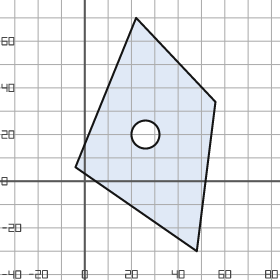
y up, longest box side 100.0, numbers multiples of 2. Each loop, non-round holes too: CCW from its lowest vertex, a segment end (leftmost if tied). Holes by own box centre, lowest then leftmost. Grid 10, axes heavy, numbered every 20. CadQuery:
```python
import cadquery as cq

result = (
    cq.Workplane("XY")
    .moveTo(48.0, -30.0)
    .lineTo(56.0, 34.0)
    .lineTo(22.0, 70.0)
    .lineTo(-4.0, 6.0)
    .close()
    .moveTo(26.0, 20.0)
    .circle(6.0)
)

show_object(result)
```